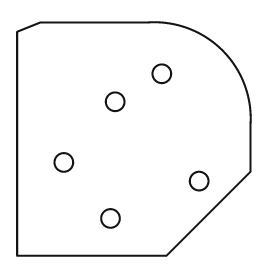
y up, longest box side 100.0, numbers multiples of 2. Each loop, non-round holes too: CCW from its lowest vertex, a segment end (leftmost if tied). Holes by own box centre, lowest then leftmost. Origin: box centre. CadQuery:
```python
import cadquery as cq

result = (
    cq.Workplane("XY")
    .moveTo(-50.0, -50.0)
    .lineTo(14.0, -50.0)
    .lineTo(50.0, -14.0)
    .lineTo(50.0, 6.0)
    .threePointArc((38.0, 38.0), (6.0, 50.0))
    .lineTo(-40.0, 50.0)
    .lineTo(-50.0, 46.0)
    .close()
    .moveTo(-10.0, -34.0)
    .circle(4.0)
    .moveTo(28.0, -18.0)
    .circle(4.0)
    .moveTo(-30.0, -10.0)
    .circle(4.0)
    .moveTo(-8.0, 16.0)
    .circle(4.0)
    .moveTo(12.0, 28.0)
    .circle(4.0)
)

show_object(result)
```